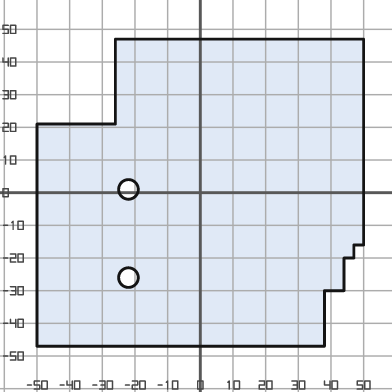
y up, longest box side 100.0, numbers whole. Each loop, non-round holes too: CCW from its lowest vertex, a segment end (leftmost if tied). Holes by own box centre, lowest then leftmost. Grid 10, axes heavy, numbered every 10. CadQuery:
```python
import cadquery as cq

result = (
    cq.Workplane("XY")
    .moveTo(-50.0, -47.0)
    .lineTo(38.0, -47.0)
    .lineTo(38.0, -30.0)
    .lineTo(44.0, -30.0)
    .lineTo(44.0, -20.0)
    .lineTo(47.0, -20.0)
    .lineTo(47.0, -16.0)
    .lineTo(50.0, -16.0)
    .lineTo(50.0, 47.0)
    .lineTo(-26.0, 47.0)
    .lineTo(-26.0, 21.0)
    .lineTo(-50.0, 21.0)
    .close()
    .moveTo(-22.0, -26.0)
    .circle(3.0)
    .moveTo(-22.0, 1.0)
    .circle(3.0)
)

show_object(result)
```